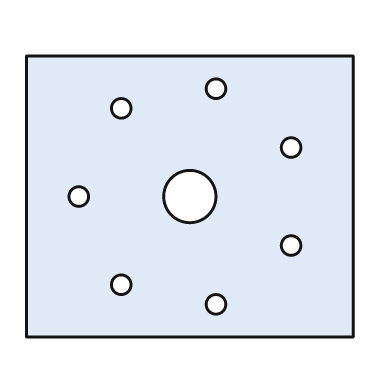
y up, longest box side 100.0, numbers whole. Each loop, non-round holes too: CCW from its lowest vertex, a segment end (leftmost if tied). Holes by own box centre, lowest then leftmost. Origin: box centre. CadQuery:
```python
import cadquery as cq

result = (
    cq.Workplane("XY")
    .moveTo(-50.0, -43.0)
    .lineTo(50.0, -43.0)
    .lineTo(50.0, 43.0)
    .lineTo(-50.0, 43.0)
    .close()
    .moveTo(8.0, -33.0)
    .circle(3.0)
    .moveTo(-21.0, -27.0)
    .circle(3.0)
    .moveTo(31.0, -15.0)
    .circle(3.0)
    .moveTo(-34.0, 0.0)
    .circle(3.0)
    .moveTo(0.0, 0.0)
    .circle(8.0)
    .moveTo(31.0, 15.0)
    .circle(3.0)
    .moveTo(-21.0, 27.0)
    .circle(3.0)
    .moveTo(8.0, 33.0)
    .circle(3.0)
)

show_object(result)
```